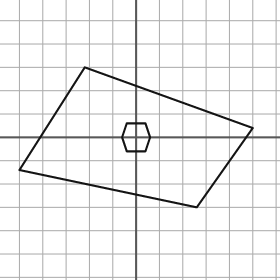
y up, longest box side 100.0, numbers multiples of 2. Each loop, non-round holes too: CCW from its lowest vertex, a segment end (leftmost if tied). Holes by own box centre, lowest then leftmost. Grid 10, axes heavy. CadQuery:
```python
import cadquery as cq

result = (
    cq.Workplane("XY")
    .moveTo(26.0, -30.0)
    .lineTo(50.0, 4.0)
    .lineTo(-22.0, 30.0)
    .lineTo(-50.0, -14.0)
    .close()
    .moveTo(-4.0, -6.0)
    .lineTo(4.0, -6.0)
    .lineTo(6.0, 0.0)
    .lineTo(4.0, 6.0)
    .lineTo(-4.0, 6.0)
    .lineTo(-6.0, 0.0)
    .close()
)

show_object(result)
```